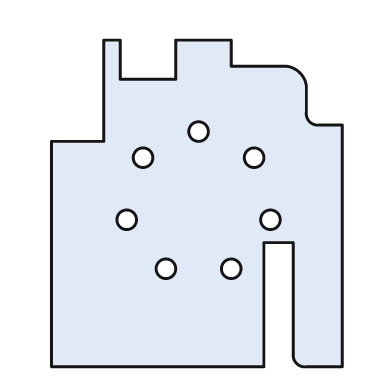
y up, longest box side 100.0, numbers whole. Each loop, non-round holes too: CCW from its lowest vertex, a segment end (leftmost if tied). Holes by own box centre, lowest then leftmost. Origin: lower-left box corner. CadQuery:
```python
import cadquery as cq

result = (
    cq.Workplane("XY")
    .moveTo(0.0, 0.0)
    .lineTo(65.0, 0.0)
    .lineTo(65.0, 38.0)
    .lineTo(74.0, 38.0)
    .lineTo(74.0, 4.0)
    .threePointArc((75.0, 1.0), (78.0, 0.0))
    .lineTo(89.0, 0.0)
    .lineTo(89.0, 74.0)
    .lineTo(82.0, 74.0)
    .threePointArc((79.0, 75.0), (78.0, 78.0))
    .lineTo(78.0, 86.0)
    .threePointArc((76.0, 90.0), (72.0, 92.0))
    .lineTo(55.0, 92.0)
    .lineTo(55.0, 100.0)
    .lineTo(38.0, 100.0)
    .lineTo(38.0, 88.0)
    .lineTo(21.0, 88.0)
    .lineTo(21.0, 100.0)
    .lineTo(16.0, 100.0)
    .lineTo(16.0, 69.0)
    .lineTo(0.0, 69.0)
    .close()
    .moveTo(35.0, 30.0)
    .circle(3.0)
    .moveTo(55.0, 30.0)
    .circle(3.0)
    .moveTo(23.0, 45.0)
    .circle(3.0)
    .moveTo(67.0, 45.0)
    .circle(3.0)
    .moveTo(28.0, 64.0)
    .circle(3.0)
    .moveTo(62.0, 64.0)
    .circle(3.0)
    .moveTo(45.0, 72.0)
    .circle(3.0)
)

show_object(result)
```